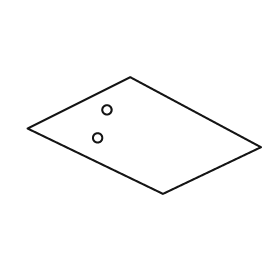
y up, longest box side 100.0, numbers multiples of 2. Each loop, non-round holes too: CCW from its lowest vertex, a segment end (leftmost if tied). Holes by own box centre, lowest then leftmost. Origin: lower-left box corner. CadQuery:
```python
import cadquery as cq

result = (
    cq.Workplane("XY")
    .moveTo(58.0, 0.0)
    .lineTo(100.0, 20.0)
    .lineTo(44.0, 50.0)
    .lineTo(0.0, 28.0)
    .close()
    .moveTo(30.0, 24.0)
    .circle(2.0)
    .moveTo(34.0, 36.0)
    .circle(2.0)
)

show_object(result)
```